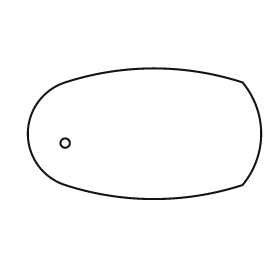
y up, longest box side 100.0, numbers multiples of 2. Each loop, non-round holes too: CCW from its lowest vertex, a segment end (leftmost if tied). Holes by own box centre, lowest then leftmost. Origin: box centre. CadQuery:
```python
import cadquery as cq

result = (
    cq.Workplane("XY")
    .moveTo(-34.0, -22.0)
    .threePointArc((4.0, -28.0), (42.0, -22.0))
    .threePointArc((50.0, 0.0), (42.0, 22.0))
    .threePointArc((4.0, 28.0), (-34.0, 22.0))
    .threePointArc((-50.0, 0.0), (-34.0, -22.0))
    .close()
    .moveTo(-34.0, -4.0)
    .circle(2.0)
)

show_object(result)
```